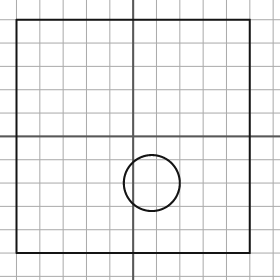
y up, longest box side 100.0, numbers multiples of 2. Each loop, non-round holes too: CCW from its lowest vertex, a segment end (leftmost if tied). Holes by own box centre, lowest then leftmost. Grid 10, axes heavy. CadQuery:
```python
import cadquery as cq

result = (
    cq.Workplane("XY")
    .moveTo(-50.0, -50.0)
    .lineTo(50.0, -50.0)
    .lineTo(50.0, 50.0)
    .lineTo(-50.0, 50.0)
    .close()
    .moveTo(8.0, -20.0)
    .circle(12.0)
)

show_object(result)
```